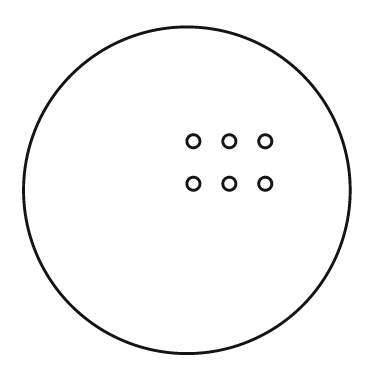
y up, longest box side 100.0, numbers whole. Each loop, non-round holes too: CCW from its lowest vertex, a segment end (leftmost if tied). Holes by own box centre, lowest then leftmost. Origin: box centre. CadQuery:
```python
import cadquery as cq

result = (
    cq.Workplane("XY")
    .moveTo(0.0, 0.0)
    .circle(50.0)
    .moveTo(2.0, 2.0)
    .circle(2.0)
    .moveTo(13.0, 2.0)
    .circle(2.0)
    .moveTo(24.0, 2.0)
    .circle(2.0)
    .moveTo(2.0, 15.0)
    .circle(2.0)
    .moveTo(13.0, 15.0)
    .circle(2.0)
    .moveTo(24.0, 15.0)
    .circle(2.0)
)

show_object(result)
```